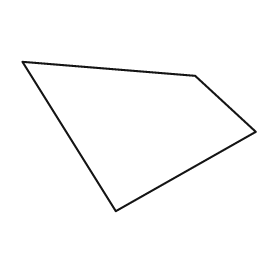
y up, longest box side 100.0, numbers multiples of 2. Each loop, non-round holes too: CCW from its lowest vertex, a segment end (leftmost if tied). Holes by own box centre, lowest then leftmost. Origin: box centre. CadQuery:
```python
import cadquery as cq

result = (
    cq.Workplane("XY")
    .moveTo(-10.0, -32.0)
    .lineTo(50.0, 2.0)
    .lineTo(24.0, 26.0)
    .lineTo(-50.0, 32.0)
    .close()
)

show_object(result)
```